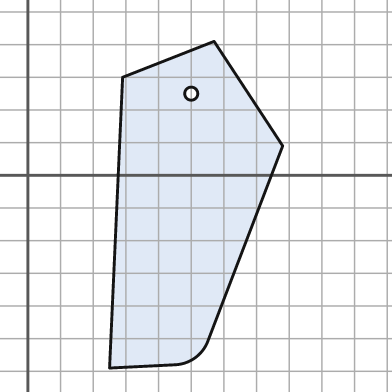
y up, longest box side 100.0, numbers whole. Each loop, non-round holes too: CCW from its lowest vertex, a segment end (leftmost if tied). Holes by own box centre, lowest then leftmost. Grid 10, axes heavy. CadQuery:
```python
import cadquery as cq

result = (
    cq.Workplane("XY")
    .moveTo(25.0, -59.0)
    .lineTo(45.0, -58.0)
    .threePointArc((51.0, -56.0), (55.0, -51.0))
    .lineTo(78.0, 9.0)
    .lineTo(57.0, 41.0)
    .lineTo(29.0, 30.0)
    .close()
    .moveTo(50.0, 25.0)
    .circle(2.0)
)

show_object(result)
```